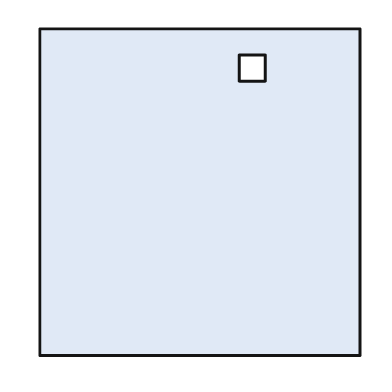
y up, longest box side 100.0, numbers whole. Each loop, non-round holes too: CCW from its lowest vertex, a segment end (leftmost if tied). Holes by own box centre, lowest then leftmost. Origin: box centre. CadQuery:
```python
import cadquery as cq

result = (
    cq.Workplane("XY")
    .moveTo(-49.0, -50.0)
    .lineTo(49.0, -50.0)
    .lineTo(49.0, 50.0)
    .lineTo(-49.0, 50.0)
    .close()
    .moveTo(12.0, 34.0)
    .lineTo(20.0, 34.0)
    .lineTo(20.0, 42.0)
    .lineTo(12.0, 42.0)
    .close()
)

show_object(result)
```